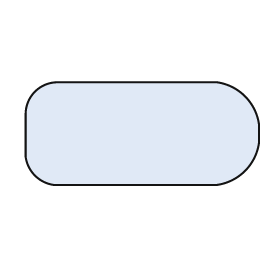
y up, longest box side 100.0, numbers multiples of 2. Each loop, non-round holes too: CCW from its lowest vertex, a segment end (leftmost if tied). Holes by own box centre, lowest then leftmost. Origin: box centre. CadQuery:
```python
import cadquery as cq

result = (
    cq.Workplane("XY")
    .moveTo(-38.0, -22.0)
    .lineTo(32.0, -22.0)
    .threePointArc((44.0, -16.0), (50.0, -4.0))
    .lineTo(50.0, 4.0)
    .threePointArc((44.0, 16.0), (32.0, 22.0))
    .lineTo(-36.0, 22.0)
    .threePointArc((-46.0, 18.0), (-50.0, 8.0))
    .lineTo(-50.0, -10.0)
    .threePointArc((-46.0, -18.0), (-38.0, -22.0))
    .close()
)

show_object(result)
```